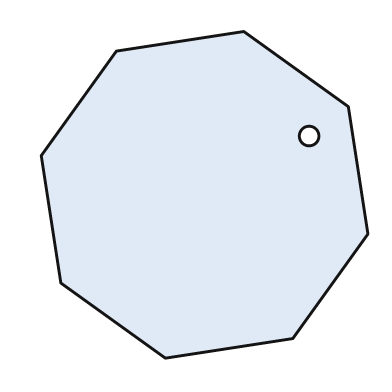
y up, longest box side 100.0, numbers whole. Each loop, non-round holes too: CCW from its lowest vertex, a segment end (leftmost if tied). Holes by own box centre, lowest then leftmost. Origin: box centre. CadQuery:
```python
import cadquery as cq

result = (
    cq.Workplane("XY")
    .moveTo(-12.0, -50.0)
    .lineTo(27.0, -44.0)
    .lineTo(50.0, -12.0)
    .lineTo(44.0, 27.0)
    .lineTo(12.0, 50.0)
    .lineTo(-27.0, 44.0)
    .lineTo(-50.0, 12.0)
    .lineTo(-44.0, -27.0)
    .close()
    .moveTo(32.0, 18.0)
    .circle(3.0)
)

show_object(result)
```